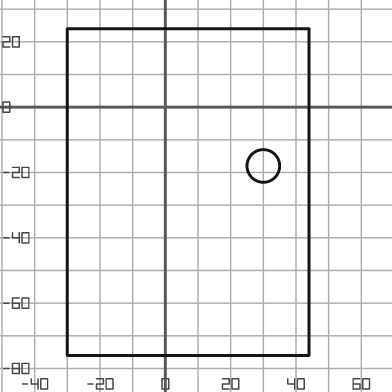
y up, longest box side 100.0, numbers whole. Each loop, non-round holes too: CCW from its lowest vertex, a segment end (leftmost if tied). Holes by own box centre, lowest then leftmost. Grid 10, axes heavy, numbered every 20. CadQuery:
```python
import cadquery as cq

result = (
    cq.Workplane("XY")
    .moveTo(-30.0, -76.0)
    .lineTo(44.0, -76.0)
    .lineTo(44.0, 24.0)
    .lineTo(-30.0, 24.0)
    .close()
    .moveTo(30.0, -18.0)
    .circle(5.0)
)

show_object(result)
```